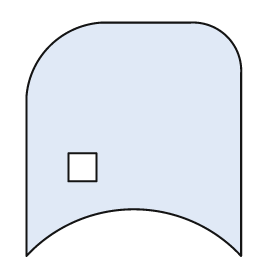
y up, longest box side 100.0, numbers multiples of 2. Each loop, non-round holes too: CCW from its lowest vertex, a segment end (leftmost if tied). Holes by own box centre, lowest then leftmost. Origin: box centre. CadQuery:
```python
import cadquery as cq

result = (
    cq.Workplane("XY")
    .moveTo(-46.0, -50.0)
    .threePointArc((0.0, -30.0), (46.0, -50.0))
    .lineTo(46.0, 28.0)
    .threePointArc((40.0, 44.0), (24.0, 50.0))
    .lineTo(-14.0, 50.0)
    .threePointArc((-36.0, 40.0), (-46.0, 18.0))
    .close()
    .moveTo(-28.0, -18.0)
    .lineTo(-16.0, -18.0)
    .lineTo(-16.0, -6.0)
    .lineTo(-28.0, -6.0)
    .close()
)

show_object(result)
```